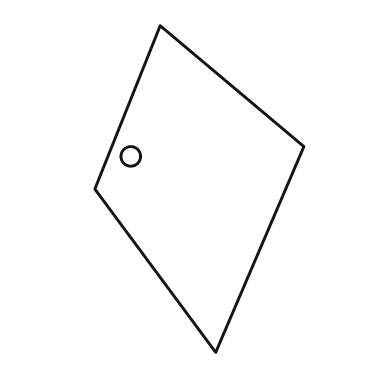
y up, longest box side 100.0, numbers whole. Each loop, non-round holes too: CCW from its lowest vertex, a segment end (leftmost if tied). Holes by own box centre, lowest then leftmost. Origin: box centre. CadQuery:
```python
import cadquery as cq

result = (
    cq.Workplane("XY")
    .moveTo(5.0, -50.0)
    .lineTo(32.0, 13.0)
    .lineTo(-12.0, 50.0)
    .lineTo(-32.0, 0.0)
    .close()
    .moveTo(-21.0, 10.0)
    .circle(3.0)
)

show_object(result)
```